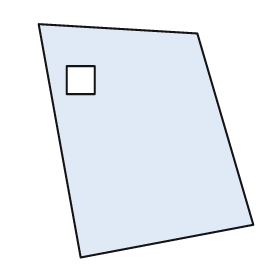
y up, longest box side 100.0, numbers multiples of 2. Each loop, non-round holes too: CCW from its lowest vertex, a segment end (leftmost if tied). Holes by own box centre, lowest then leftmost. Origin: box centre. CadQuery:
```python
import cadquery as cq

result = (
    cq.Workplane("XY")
    .moveTo(-28.0, -50.0)
    .lineTo(46.0, -36.0)
    .lineTo(22.0, 46.0)
    .lineTo(-46.0, 50.0)
    .close()
    .moveTo(-34.0, 20.0)
    .lineTo(-22.0, 20.0)
    .lineTo(-22.0, 32.0)
    .lineTo(-34.0, 32.0)
    .close()
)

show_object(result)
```